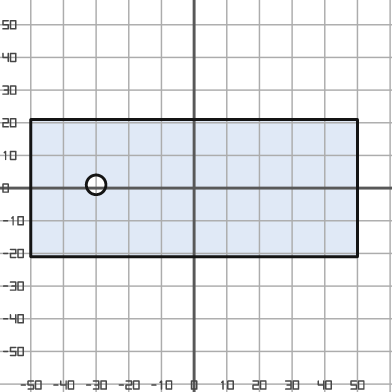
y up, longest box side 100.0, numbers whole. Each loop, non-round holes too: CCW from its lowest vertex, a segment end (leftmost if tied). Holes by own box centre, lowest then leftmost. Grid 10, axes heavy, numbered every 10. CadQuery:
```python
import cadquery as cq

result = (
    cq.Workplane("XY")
    .moveTo(-50.0, -21.0)
    .lineTo(50.0, -21.0)
    .lineTo(50.0, 21.0)
    .lineTo(-50.0, 21.0)
    .close()
    .moveTo(-30.0, 1.0)
    .circle(3.0)
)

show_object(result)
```